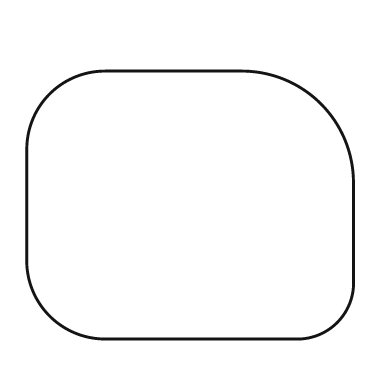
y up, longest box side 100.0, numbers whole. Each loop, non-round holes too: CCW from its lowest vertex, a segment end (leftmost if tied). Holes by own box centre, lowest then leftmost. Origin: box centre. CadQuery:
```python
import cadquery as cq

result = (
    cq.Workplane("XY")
    .moveTo(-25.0, -41.0)
    .lineTo(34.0, -41.0)
    .threePointArc((45.0, -36.0), (50.0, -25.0))
    .lineTo(50.0, 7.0)
    .threePointArc((40.0, 31.0), (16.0, 41.0))
    .lineTo(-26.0, 41.0)
    .threePointArc((-43.0, 34.0), (-50.0, 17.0))
    .lineTo(-50.0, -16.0)
    .threePointArc((-43.0, -34.0), (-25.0, -41.0))
    .close()
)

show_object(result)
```